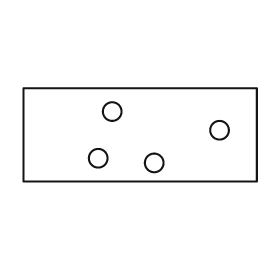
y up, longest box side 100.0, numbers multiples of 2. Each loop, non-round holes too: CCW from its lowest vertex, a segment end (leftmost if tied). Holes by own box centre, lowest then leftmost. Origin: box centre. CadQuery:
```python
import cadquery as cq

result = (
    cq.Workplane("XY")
    .moveTo(-50.0, -20.0)
    .lineTo(50.0, -20.0)
    .lineTo(50.0, 20.0)
    .lineTo(-50.0, 20.0)
    .close()
    .moveTo(6.0, -12.0)
    .circle(4.0)
    .moveTo(-18.0, -10.0)
    .circle(4.0)
    .moveTo(34.0, 2.0)
    .circle(4.0)
    .moveTo(-12.0, 10.0)
    .circle(4.0)
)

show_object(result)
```